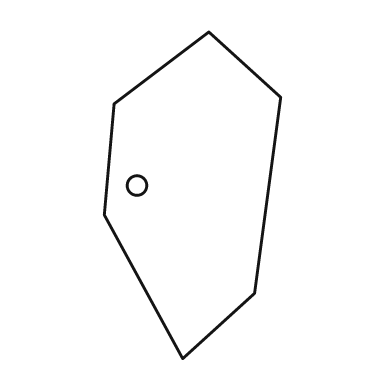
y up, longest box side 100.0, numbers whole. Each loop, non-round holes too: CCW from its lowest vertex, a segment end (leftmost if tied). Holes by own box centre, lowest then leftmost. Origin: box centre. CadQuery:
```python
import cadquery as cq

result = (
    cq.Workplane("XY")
    .moveTo(-3.0, -50.0)
    .lineTo(19.0, -30.0)
    .lineTo(27.0, 30.0)
    .lineTo(5.0, 50.0)
    .lineTo(-24.0, 28.0)
    .lineTo(-27.0, -6.0)
    .close()
    .moveTo(-17.0, 3.0)
    .circle(3.0)
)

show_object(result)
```